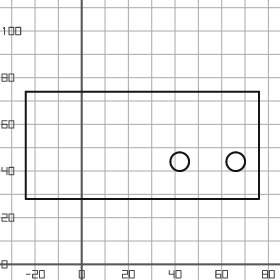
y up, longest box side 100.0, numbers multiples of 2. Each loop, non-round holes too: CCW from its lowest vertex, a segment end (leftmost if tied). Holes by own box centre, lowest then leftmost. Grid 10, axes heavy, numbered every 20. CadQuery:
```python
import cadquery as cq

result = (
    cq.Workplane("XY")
    .moveTo(-24.0, 28.0)
    .lineTo(76.0, 28.0)
    .lineTo(76.0, 74.0)
    .lineTo(-24.0, 74.0)
    .close()
    .moveTo(42.0, 44.0)
    .circle(4.0)
    .moveTo(66.0, 44.0)
    .circle(4.0)
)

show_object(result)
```